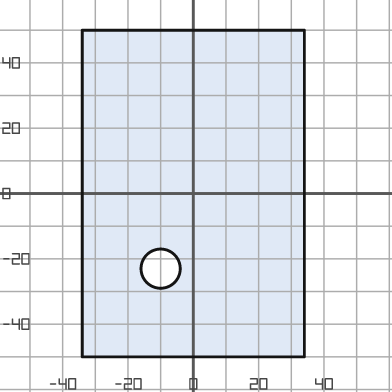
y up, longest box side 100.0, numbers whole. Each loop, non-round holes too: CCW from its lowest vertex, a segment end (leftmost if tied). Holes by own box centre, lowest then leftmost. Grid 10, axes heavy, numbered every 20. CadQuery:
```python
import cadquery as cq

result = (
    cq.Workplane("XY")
    .moveTo(-34.0, -50.0)
    .lineTo(34.0, -50.0)
    .lineTo(34.0, 50.0)
    .lineTo(-34.0, 50.0)
    .close()
    .moveTo(-10.0, -23.0)
    .circle(6.0)
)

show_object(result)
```